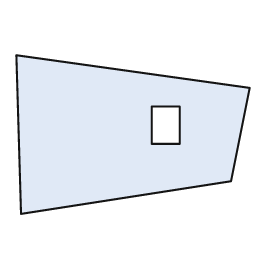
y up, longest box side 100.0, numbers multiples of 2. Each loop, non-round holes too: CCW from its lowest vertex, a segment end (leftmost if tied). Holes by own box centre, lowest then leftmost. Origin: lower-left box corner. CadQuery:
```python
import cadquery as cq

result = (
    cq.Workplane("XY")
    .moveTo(2.0, 0.0)
    .lineTo(92.0, 14.0)
    .lineTo(100.0, 54.0)
    .lineTo(0.0, 68.0)
    .close()
    .moveTo(58.0, 30.0)
    .lineTo(70.0, 30.0)
    .lineTo(70.0, 46.0)
    .lineTo(58.0, 46.0)
    .close()
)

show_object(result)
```